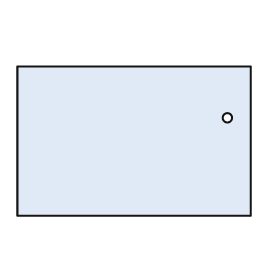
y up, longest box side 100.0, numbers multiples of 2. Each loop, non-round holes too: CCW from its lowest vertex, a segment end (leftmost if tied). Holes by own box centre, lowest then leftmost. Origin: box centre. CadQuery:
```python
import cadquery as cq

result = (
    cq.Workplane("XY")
    .moveTo(-50.0, -32.0)
    .lineTo(50.0, -32.0)
    .lineTo(50.0, 32.0)
    .lineTo(-50.0, 32.0)
    .close()
    .moveTo(40.0, 10.0)
    .circle(2.0)
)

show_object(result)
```